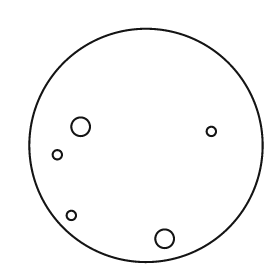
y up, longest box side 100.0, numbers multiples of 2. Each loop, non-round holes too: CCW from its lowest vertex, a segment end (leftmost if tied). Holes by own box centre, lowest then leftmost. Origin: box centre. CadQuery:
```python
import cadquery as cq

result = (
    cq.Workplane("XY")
    .moveTo(0.0, 0.0)
    .circle(50.0)
    .moveTo(8.0, -40.0)
    .circle(4.0)
    .moveTo(-32.0, -30.0)
    .circle(2.0)
    .moveTo(-38.0, -4.0)
    .circle(2.0)
    .moveTo(28.0, 6.0)
    .circle(2.0)
    .moveTo(-28.0, 8.0)
    .circle(4.0)
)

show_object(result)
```